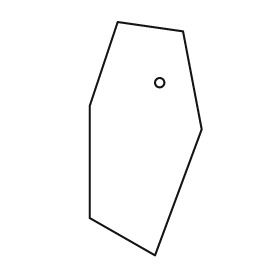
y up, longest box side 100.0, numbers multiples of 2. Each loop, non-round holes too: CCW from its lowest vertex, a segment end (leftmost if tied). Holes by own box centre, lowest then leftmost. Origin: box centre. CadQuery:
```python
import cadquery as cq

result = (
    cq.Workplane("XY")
    .moveTo(4.0, -50.0)
    .lineTo(24.0, 4.0)
    .lineTo(16.0, 46.0)
    .lineTo(-12.0, 50.0)
    .lineTo(-24.0, 14.0)
    .lineTo(-24.0, -34.0)
    .close()
    .moveTo(6.0, 24.0)
    .circle(2.0)
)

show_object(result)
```